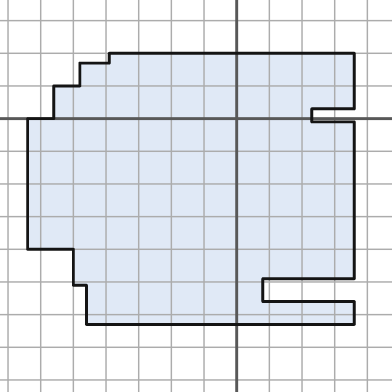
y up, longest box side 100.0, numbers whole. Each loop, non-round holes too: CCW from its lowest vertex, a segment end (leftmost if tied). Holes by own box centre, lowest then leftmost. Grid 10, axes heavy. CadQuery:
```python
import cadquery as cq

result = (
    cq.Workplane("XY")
    .moveTo(-46.0, -63.0)
    .lineTo(36.0, -63.0)
    .lineTo(36.0, -56.0)
    .lineTo(8.0, -56.0)
    .lineTo(8.0, -49.0)
    .lineTo(36.0, -49.0)
    .lineTo(36.0, -1.0)
    .lineTo(23.0, -1.0)
    .lineTo(23.0, 3.0)
    .lineTo(36.0, 3.0)
    .lineTo(36.0, 20.0)
    .lineTo(-39.0, 20.0)
    .lineTo(-39.0, 17.0)
    .lineTo(-48.0, 17.0)
    .lineTo(-48.0, 10.0)
    .lineTo(-56.0, 10.0)
    .lineTo(-56.0, 0.0)
    .lineTo(-64.0, 0.0)
    .lineTo(-64.0, -40.0)
    .lineTo(-50.0, -40.0)
    .lineTo(-50.0, -51.0)
    .lineTo(-46.0, -51.0)
    .close()
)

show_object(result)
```